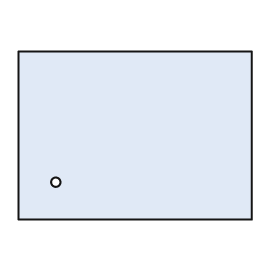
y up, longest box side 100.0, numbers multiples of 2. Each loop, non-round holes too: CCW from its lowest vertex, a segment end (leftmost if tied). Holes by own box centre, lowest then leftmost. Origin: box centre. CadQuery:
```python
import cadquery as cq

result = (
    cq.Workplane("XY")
    .moveTo(-50.0, -36.0)
    .lineTo(50.0, -36.0)
    .lineTo(50.0, 36.0)
    .lineTo(-50.0, 36.0)
    .close()
    .moveTo(-34.0, -20.0)
    .circle(2.0)
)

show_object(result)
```